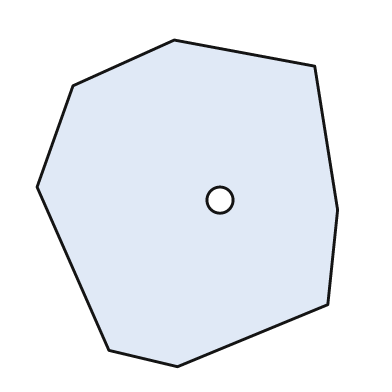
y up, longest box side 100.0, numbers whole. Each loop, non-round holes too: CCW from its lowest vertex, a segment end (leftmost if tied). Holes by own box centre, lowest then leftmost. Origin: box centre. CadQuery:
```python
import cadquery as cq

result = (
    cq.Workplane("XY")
    .moveTo(-3.0, -50.0)
    .lineTo(43.0, -31.0)
    .lineTo(46.0, -2.0)
    .lineTo(39.0, 42.0)
    .lineTo(-4.0, 50.0)
    .lineTo(-35.0, 36.0)
    .lineTo(-46.0, 5.0)
    .lineTo(-24.0, -45.0)
    .close()
    .moveTo(10.0, 1.0)
    .circle(4.0)
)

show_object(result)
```